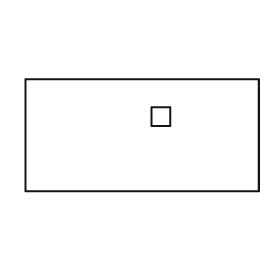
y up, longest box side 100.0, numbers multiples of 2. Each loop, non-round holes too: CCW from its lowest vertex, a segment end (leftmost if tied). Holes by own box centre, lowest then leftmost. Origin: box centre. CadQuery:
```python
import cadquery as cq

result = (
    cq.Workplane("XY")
    .moveTo(-50.0, -24.0)
    .lineTo(50.0, -24.0)
    .lineTo(50.0, 24.0)
    .lineTo(-50.0, 24.0)
    .close()
    .moveTo(4.0, 4.0)
    .lineTo(12.0, 4.0)
    .lineTo(12.0, 12.0)
    .lineTo(4.0, 12.0)
    .close()
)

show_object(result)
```